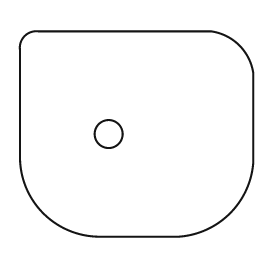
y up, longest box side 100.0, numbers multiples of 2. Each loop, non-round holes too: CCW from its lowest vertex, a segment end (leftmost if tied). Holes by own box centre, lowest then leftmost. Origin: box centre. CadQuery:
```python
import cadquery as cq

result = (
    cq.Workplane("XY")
    .moveTo(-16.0, -44.0)
    .lineTo(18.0, -44.0)
    .threePointArc((40.0, -34.0), (50.0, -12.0))
    .lineTo(50.0, 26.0)
    .threePointArc((44.0, 38.0), (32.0, 44.0))
    .lineTo(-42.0, 44.0)
    .threePointArc((-48.0, 42.0), (-50.0, 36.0))
    .lineTo(-50.0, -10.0)
    .threePointArc((-40.0, -34.0), (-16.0, -44.0))
    .close()
    .moveTo(-12.0, 0.0)
    .circle(6.0)
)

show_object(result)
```